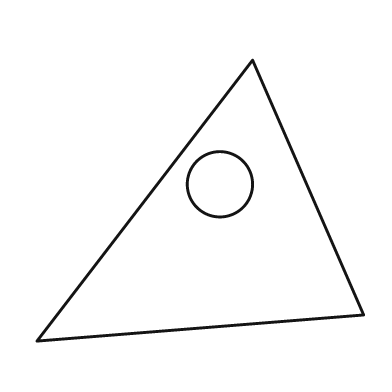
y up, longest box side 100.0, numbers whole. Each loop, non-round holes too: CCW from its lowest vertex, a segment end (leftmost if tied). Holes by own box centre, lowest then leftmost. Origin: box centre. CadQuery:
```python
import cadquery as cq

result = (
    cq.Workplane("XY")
    .moveTo(-50.0, -43.0)
    .lineTo(50.0, -35.0)
    .lineTo(16.0, 43.0)
    .close()
    .moveTo(6.0, 5.0)
    .circle(10.0)
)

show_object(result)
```